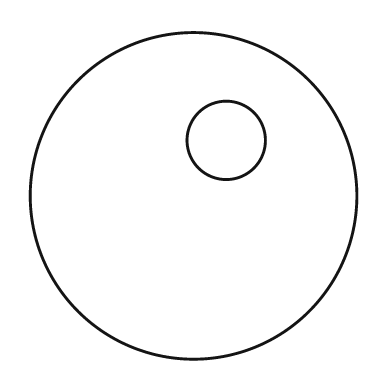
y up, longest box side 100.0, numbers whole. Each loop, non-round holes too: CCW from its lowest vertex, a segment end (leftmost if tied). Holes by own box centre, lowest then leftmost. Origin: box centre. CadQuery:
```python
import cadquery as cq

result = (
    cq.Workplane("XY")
    .moveTo(0.0, 0.0)
    .circle(50.0)
    .moveTo(10.0, 17.0)
    .circle(12.0)
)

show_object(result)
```